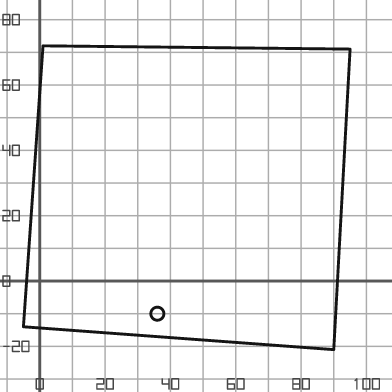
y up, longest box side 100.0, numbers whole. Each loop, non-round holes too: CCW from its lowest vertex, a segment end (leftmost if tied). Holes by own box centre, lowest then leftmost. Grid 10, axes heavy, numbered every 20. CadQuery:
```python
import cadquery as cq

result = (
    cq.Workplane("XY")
    .moveTo(90.0, -21.0)
    .lineTo(95.0, 71.0)
    .lineTo(1.0, 72.0)
    .lineTo(-5.0, -14.0)
    .close()
    .moveTo(36.0, -10.0)
    .circle(2.0)
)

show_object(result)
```